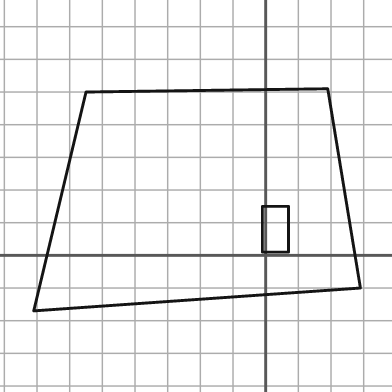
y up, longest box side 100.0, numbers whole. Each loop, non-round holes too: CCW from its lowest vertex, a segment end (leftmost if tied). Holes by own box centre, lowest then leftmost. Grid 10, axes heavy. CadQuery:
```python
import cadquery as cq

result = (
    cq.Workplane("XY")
    .moveTo(-71.0, -17.0)
    .lineTo(29.0, -10.0)
    .lineTo(19.0, 51.0)
    .lineTo(-55.0, 50.0)
    .close()
    .moveTo(-1.0, 1.0)
    .lineTo(7.0, 1.0)
    .lineTo(7.0, 15.0)
    .lineTo(-1.0, 15.0)
    .close()
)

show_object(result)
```